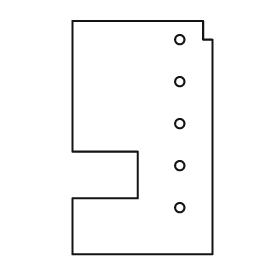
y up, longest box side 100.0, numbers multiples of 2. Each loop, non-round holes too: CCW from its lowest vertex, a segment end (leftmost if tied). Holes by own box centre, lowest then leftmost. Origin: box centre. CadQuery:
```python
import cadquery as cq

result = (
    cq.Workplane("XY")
    .moveTo(-30.0, -50.0)
    .lineTo(30.0, -50.0)
    .lineTo(30.0, 42.0)
    .lineTo(26.0, 42.0)
    .lineTo(26.0, 50.0)
    .lineTo(-30.0, 50.0)
    .lineTo(-30.0, -6.0)
    .lineTo(-2.0, -6.0)
    .lineTo(-2.0, -26.0)
    .lineTo(-30.0, -26.0)
    .close()
    .moveTo(16.0, -30.0)
    .circle(2.0)
    .moveTo(16.0, -12.0)
    .circle(2.0)
    .moveTo(16.0, 6.0)
    .circle(2.0)
    .moveTo(16.0, 24.0)
    .circle(2.0)
    .moveTo(16.0, 42.0)
    .circle(2.0)
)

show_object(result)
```